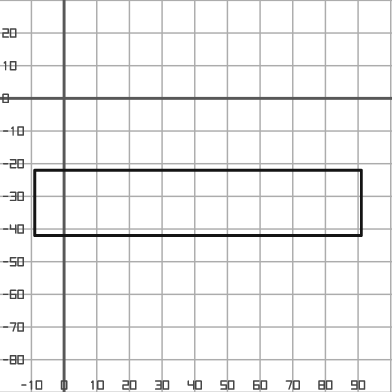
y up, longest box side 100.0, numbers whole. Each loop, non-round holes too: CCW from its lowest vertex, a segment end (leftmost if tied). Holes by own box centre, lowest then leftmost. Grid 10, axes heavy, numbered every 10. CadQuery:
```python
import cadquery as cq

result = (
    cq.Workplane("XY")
    .moveTo(-9.0, -42.0)
    .lineTo(91.0, -42.0)
    .lineTo(91.0, -22.0)
    .lineTo(-9.0, -22.0)
    .close()
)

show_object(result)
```